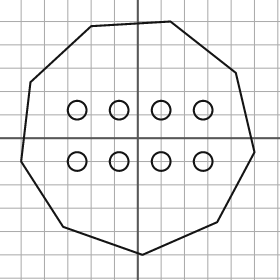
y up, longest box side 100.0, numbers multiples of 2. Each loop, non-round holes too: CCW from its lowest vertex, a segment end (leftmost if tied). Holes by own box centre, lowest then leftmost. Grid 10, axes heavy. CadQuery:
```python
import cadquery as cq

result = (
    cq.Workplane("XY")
    .moveTo(2.0, -50.0)
    .lineTo(34.0, -36.0)
    .lineTo(50.0, -6.0)
    .lineTo(42.0, 28.0)
    .lineTo(14.0, 50.0)
    .lineTo(-20.0, 48.0)
    .lineTo(-46.0, 24.0)
    .lineTo(-50.0, -10.0)
    .lineTo(-32.0, -38.0)
    .close()
    .moveTo(-26.0, -10.0)
    .circle(4.0)
    .moveTo(-8.0, -10.0)
    .circle(4.0)
    .moveTo(10.0, -10.0)
    .circle(4.0)
    .moveTo(28.0, -10.0)
    .circle(4.0)
    .moveTo(-26.0, 12.0)
    .circle(4.0)
    .moveTo(-8.0, 12.0)
    .circle(4.0)
    .moveTo(10.0, 12.0)
    .circle(4.0)
    .moveTo(28.0, 12.0)
    .circle(4.0)
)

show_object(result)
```